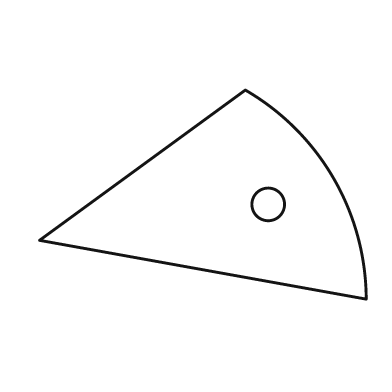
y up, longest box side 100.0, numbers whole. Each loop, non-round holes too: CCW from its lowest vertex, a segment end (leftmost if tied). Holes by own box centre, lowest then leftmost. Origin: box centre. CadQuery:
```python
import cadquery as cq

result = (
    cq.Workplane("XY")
    .moveTo(50.0, -32.0)
    .threePointArc((40.0, 5.0), (13.0, 32.0))
    .lineTo(-50.0, -14.0)
    .close()
    .moveTo(20.0, -3.0)
    .circle(5.0)
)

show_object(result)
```